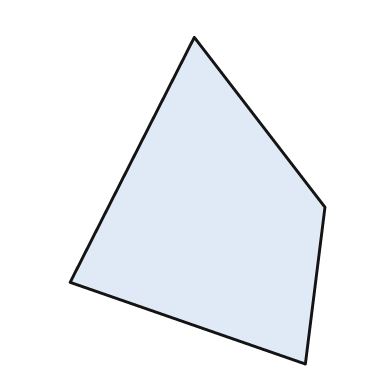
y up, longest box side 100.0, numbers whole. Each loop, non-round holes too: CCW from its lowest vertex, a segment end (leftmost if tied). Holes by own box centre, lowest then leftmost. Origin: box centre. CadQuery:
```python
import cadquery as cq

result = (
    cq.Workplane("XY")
    .moveTo(33.0, -50.0)
    .lineTo(39.0, -2.0)
    .lineTo(-1.0, 50.0)
    .lineTo(-39.0, -25.0)
    .close()
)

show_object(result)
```